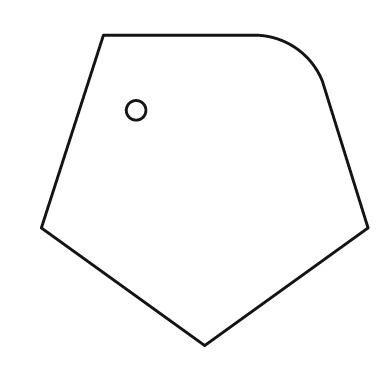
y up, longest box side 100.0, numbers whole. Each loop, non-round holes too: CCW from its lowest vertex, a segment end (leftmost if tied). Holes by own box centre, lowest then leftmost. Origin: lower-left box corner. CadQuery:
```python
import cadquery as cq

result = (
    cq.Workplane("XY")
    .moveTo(50.0, 0.0)
    .lineTo(100.0, 36.0)
    .lineTo(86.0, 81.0)
    .threePointArc((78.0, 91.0), (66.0, 95.0))
    .lineTo(19.0, 95.0)
    .lineTo(0.0, 36.0)
    .close()
    .moveTo(29.0, 72.0)
    .circle(3.0)
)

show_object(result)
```